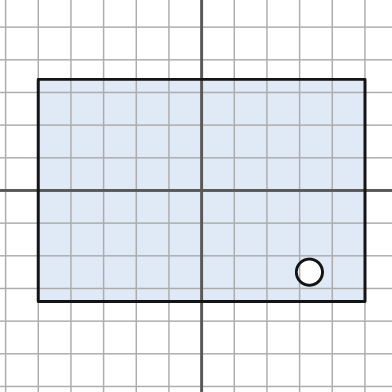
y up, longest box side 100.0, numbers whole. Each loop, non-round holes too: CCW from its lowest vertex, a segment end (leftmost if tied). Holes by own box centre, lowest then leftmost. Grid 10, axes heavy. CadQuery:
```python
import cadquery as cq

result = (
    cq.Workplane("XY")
    .moveTo(-50.0, -34.0)
    .lineTo(50.0, -34.0)
    .lineTo(50.0, 34.0)
    .lineTo(-50.0, 34.0)
    .close()
    .moveTo(33.0, -25.0)
    .circle(4.0)
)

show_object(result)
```